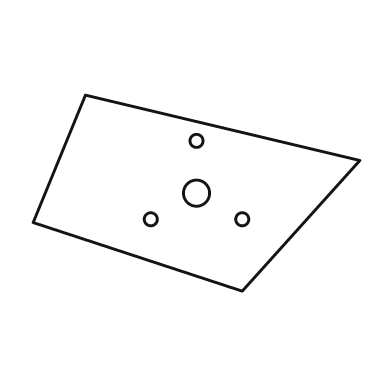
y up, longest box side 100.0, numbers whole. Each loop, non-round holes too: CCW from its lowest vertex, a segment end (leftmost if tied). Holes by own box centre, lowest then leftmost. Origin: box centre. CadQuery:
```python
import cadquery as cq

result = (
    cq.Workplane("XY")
    .moveTo(14.0, -30.0)
    .lineTo(50.0, 10.0)
    .lineTo(-34.0, 30.0)
    .lineTo(-50.0, -9.0)
    .close()
    .moveTo(-14.0, -8.0)
    .circle(2.0)
    .moveTo(14.0, -8.0)
    .circle(2.0)
    .moveTo(0.0, 0.0)
    .circle(4.0)
    .moveTo(0.0, 16.0)
    .circle(2.0)
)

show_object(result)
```